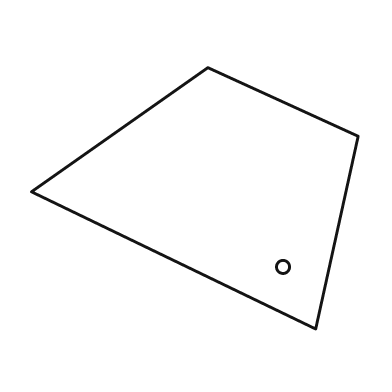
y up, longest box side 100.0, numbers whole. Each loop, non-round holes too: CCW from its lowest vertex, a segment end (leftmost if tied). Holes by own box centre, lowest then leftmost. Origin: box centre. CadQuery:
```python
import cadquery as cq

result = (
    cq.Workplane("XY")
    .moveTo(37.0, -40.0)
    .lineTo(50.0, 19.0)
    .lineTo(4.0, 40.0)
    .lineTo(-50.0, 2.0)
    .close()
    .moveTo(27.0, -21.0)
    .circle(2.0)
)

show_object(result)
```